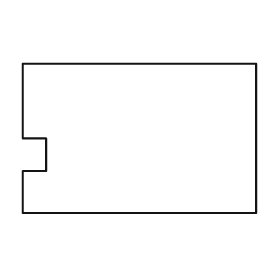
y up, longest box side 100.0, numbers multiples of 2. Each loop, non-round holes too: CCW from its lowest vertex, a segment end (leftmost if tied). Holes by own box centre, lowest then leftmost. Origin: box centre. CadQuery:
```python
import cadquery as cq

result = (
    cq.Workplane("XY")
    .moveTo(-50.0, -32.0)
    .lineTo(50.0, -32.0)
    .lineTo(50.0, 32.0)
    .lineTo(-50.0, 32.0)
    .lineTo(-50.0, 0.0)
    .lineTo(-40.0, 0.0)
    .lineTo(-40.0, -14.0)
    .lineTo(-50.0, -14.0)
    .close()
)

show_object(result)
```